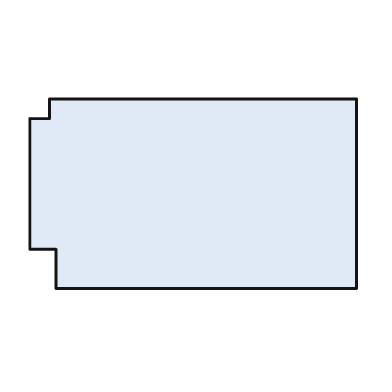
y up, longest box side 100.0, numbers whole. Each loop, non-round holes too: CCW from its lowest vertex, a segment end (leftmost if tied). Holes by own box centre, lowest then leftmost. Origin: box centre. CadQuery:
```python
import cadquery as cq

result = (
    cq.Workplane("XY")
    .moveTo(-42.0, -29.0)
    .lineTo(50.0, -29.0)
    .lineTo(50.0, 29.0)
    .lineTo(-44.0, 29.0)
    .lineTo(-44.0, 23.0)
    .lineTo(-50.0, 23.0)
    .lineTo(-50.0, -17.0)
    .lineTo(-42.0, -17.0)
    .close()
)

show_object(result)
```